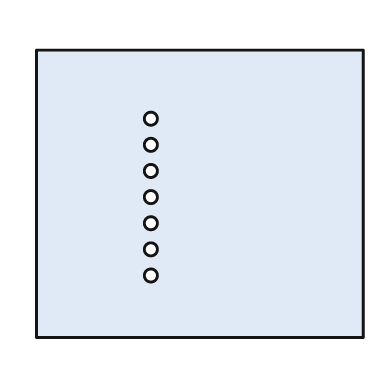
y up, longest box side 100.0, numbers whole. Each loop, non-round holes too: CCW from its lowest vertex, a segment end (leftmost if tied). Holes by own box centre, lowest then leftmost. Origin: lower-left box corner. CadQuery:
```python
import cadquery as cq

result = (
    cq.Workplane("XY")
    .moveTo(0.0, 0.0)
    .lineTo(100.0, 0.0)
    .lineTo(100.0, 88.0)
    .lineTo(0.0, 88.0)
    .close()
    .moveTo(35.0, 19.0)
    .circle(2.0)
    .moveTo(35.0, 27.0)
    .circle(2.0)
    .moveTo(35.0, 35.0)
    .circle(2.0)
    .moveTo(35.0, 43.0)
    .circle(2.0)
    .moveTo(35.0, 51.0)
    .circle(2.0)
    .moveTo(35.0, 59.0)
    .circle(2.0)
    .moveTo(35.0, 67.0)
    .circle(2.0)
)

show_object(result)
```